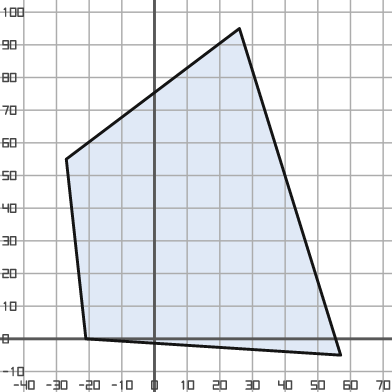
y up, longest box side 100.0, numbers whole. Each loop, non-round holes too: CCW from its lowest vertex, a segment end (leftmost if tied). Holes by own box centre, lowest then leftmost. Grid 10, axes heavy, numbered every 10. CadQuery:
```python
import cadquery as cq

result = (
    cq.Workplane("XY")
    .moveTo(57.0, -5.0)
    .lineTo(26.0, 95.0)
    .lineTo(-27.0, 55.0)
    .lineTo(-21.0, 0.0)
    .close()
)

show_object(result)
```